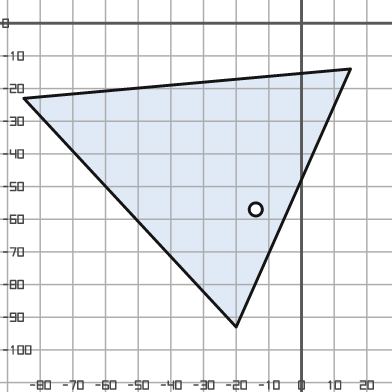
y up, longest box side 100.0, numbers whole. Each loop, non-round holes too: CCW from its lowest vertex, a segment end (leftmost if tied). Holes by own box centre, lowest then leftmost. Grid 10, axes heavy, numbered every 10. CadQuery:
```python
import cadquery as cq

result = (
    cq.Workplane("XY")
    .moveTo(-20.0, -93.0)
    .lineTo(15.0, -14.0)
    .lineTo(-85.0, -23.0)
    .close()
    .moveTo(-14.0, -57.0)
    .circle(2.0)
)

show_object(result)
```